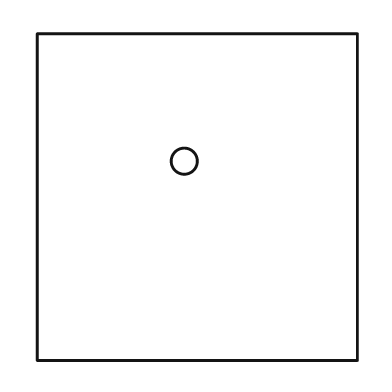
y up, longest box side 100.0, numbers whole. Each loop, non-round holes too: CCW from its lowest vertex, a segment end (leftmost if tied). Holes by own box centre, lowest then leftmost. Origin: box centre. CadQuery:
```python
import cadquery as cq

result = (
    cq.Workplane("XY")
    .moveTo(-49.0, -50.0)
    .lineTo(49.0, -50.0)
    .lineTo(49.0, 50.0)
    .lineTo(-49.0, 50.0)
    .close()
    .moveTo(-4.0, 11.0)
    .circle(4.0)
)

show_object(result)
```